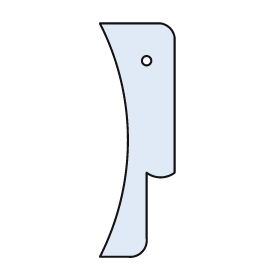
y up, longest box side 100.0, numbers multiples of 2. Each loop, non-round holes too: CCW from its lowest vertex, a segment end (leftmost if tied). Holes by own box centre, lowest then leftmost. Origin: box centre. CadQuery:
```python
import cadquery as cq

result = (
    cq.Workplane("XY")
    .moveTo(-16.0, -50.0)
    .lineTo(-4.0, -50.0)
    .threePointArc((2.0, -48.0), (4.0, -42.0))
    .lineTo(4.0, -14.0)
    .threePointArc((10.0, -16.0), (16.0, -14.0))
    .lineTo(16.0, 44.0)
    .threePointArc((14.0, 48.0), (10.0, 50.0))
    .lineTo(-16.0, 50.0)
    .threePointArc((-4.0, 0.0), (-16.0, -50.0))
    .close()
    .moveTo(4.0, 34.0)
    .circle(2.0)
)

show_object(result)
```